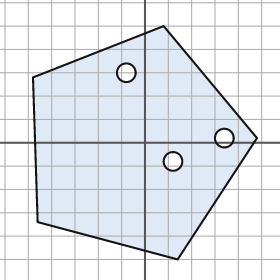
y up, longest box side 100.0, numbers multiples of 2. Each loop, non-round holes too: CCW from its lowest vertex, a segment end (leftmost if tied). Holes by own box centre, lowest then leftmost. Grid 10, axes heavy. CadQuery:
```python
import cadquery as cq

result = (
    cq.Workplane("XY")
    .moveTo(14.0, -50.0)
    .lineTo(48.0, 2.0)
    .lineTo(8.0, 50.0)
    .lineTo(-48.0, 28.0)
    .lineTo(-46.0, -34.0)
    .close()
    .moveTo(12.0, -8.0)
    .circle(4.0)
    .moveTo(34.0, 2.0)
    .circle(4.0)
    .moveTo(-8.0, 30.0)
    .circle(4.0)
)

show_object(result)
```